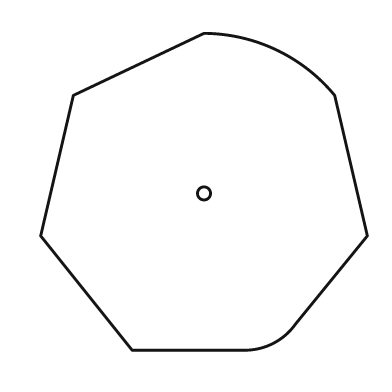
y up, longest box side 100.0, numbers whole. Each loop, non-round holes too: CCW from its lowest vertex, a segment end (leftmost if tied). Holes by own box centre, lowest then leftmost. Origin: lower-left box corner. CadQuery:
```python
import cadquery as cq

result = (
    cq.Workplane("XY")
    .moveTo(28.0, 0.0)
    .lineTo(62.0, 0.0)
    .threePointArc((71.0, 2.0), (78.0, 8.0))
    .lineTo(100.0, 35.0)
    .lineTo(90.0, 78.0)
    .threePointArc((72.0, 92.0), (50.0, 97.0))
    .lineTo(10.0, 78.0)
    .lineTo(0.0, 35.0)
    .close()
    .moveTo(50.0, 48.0)
    .circle(2.0)
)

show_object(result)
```